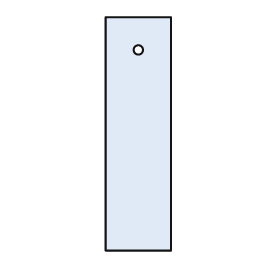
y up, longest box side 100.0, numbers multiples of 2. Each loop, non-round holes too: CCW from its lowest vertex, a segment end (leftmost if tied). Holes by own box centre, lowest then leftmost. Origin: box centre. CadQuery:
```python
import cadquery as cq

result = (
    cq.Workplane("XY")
    .moveTo(-14.0, -50.0)
    .lineTo(14.0, -50.0)
    .lineTo(14.0, 50.0)
    .lineTo(-14.0, 50.0)
    .close()
    .moveTo(0.0, 36.0)
    .circle(2.0)
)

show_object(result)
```